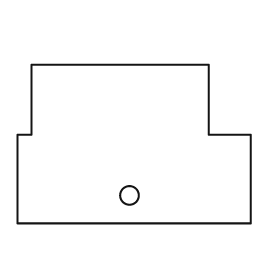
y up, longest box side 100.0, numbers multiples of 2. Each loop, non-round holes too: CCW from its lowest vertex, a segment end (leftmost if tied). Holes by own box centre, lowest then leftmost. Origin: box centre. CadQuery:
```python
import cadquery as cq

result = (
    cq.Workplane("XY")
    .moveTo(-50.0, -34.0)
    .lineTo(50.0, -34.0)
    .lineTo(50.0, 4.0)
    .lineTo(32.0, 4.0)
    .lineTo(32.0, 34.0)
    .lineTo(-44.0, 34.0)
    .lineTo(-44.0, 4.0)
    .lineTo(-50.0, 4.0)
    .close()
    .moveTo(-2.0, -22.0)
    .circle(4.0)
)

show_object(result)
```